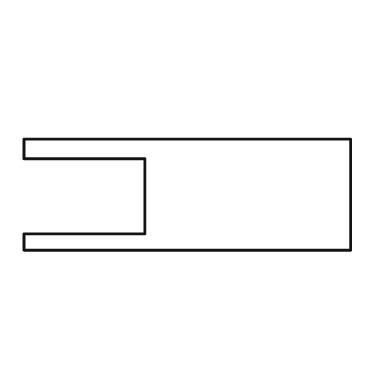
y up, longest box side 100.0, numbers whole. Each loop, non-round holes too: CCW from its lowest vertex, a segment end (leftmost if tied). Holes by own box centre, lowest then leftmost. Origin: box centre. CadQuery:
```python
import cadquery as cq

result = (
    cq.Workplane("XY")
    .moveTo(-50.0, -17.0)
    .lineTo(50.0, -17.0)
    .lineTo(50.0, 17.0)
    .lineTo(-50.0, 17.0)
    .lineTo(-50.0, 11.0)
    .lineTo(-13.0, 11.0)
    .lineTo(-13.0, -12.0)
    .lineTo(-50.0, -12.0)
    .close()
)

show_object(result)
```